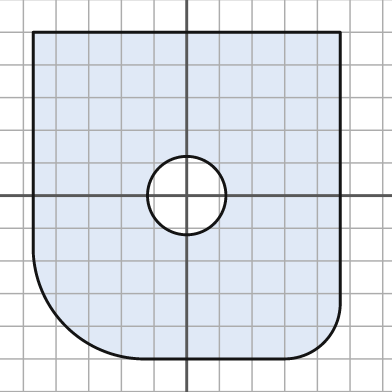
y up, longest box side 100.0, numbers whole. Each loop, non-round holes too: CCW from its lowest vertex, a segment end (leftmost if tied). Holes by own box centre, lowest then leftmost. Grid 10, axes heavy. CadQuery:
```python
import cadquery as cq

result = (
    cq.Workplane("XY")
    .moveTo(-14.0, -50.0)
    .lineTo(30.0, -50.0)
    .threePointArc((42.0, -45.0), (47.0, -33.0))
    .lineTo(47.0, 50.0)
    .lineTo(-47.0, 50.0)
    .lineTo(-47.0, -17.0)
    .threePointArc((-37.0, -40.0), (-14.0, -50.0))
    .close()
    .moveTo(0.0, 0.0)
    .circle(12.0)
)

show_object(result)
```